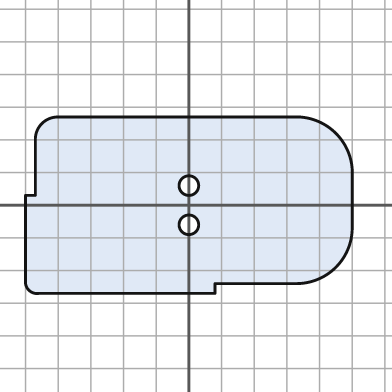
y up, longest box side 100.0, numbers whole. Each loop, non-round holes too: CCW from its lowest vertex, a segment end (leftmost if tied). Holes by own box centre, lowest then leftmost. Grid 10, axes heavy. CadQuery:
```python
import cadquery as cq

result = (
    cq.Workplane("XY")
    .moveTo(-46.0, -27.0)
    .lineTo(8.0, -27.0)
    .lineTo(8.0, -24.0)
    .lineTo(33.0, -24.0)
    .threePointArc((45.0, -19.0), (50.0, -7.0))
    .lineTo(50.0, 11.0)
    .threePointArc((45.0, 22.0), (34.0, 27.0))
    .lineTo(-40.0, 27.0)
    .threePointArc((-45.0, 25.0), (-47.0, 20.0))
    .lineTo(-47.0, 3.0)
    .lineTo(-50.0, 3.0)
    .lineTo(-50.0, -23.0)
    .threePointArc((-49.0, -26.0), (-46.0, -27.0))
    .close()
    .moveTo(0.0, -6.0)
    .circle(3.0)
    .moveTo(0.0, 6.0)
    .circle(3.0)
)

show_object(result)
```